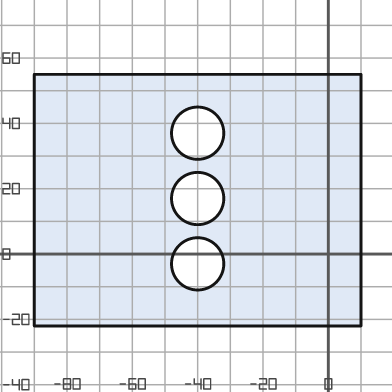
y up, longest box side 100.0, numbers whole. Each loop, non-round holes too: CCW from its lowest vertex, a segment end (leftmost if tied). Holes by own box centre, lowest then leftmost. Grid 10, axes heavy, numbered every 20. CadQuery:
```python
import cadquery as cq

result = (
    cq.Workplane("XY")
    .moveTo(-90.0, -22.0)
    .lineTo(10.0, -22.0)
    .lineTo(10.0, 55.0)
    .lineTo(-90.0, 55.0)
    .close()
    .moveTo(-40.0, -3.0)
    .circle(8.0)
    .moveTo(-40.0, 17.0)
    .circle(8.0)
    .moveTo(-40.0, 37.0)
    .circle(8.0)
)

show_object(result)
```